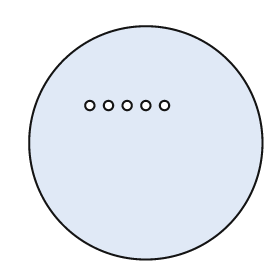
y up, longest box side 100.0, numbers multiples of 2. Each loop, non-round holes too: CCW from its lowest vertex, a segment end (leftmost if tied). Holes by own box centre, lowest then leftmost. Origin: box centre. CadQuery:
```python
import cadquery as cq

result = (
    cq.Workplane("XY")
    .moveTo(0.0, 0.0)
    .circle(50.0)
    .moveTo(-24.0, 16.0)
    .circle(2.0)
    .moveTo(-16.0, 16.0)
    .circle(2.0)
    .moveTo(-8.0, 16.0)
    .circle(2.0)
    .moveTo(0.0, 16.0)
    .circle(2.0)
    .moveTo(8.0, 16.0)
    .circle(2.0)
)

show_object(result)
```